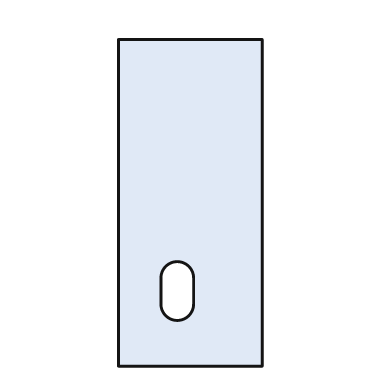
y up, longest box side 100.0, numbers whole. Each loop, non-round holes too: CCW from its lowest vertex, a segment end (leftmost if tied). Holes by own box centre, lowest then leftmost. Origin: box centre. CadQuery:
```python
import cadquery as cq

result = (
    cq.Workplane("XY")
    .moveTo(-22.0, -50.0)
    .lineTo(22.0, -50.0)
    .lineTo(22.0, 50.0)
    .lineTo(-22.0, 50.0)
    .close()
    .moveTo(-9.0, -31.0)
    .threePointArc((-4.0, -36.0), (1.0, -31.0))
    .lineTo(1.0, -23.0)
    .threePointArc((-4.0, -18.0), (-9.0, -23.0))
    .close()
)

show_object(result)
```